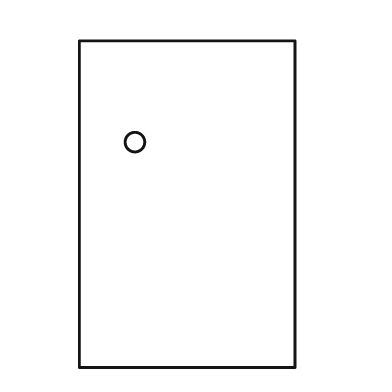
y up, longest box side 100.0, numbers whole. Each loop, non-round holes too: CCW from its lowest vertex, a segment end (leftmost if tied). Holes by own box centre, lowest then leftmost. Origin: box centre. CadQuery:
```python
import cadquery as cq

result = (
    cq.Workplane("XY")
    .moveTo(-33.0, -50.0)
    .lineTo(33.0, -50.0)
    .lineTo(33.0, 50.0)
    .lineTo(-33.0, 50.0)
    .close()
    .moveTo(-16.0, 19.0)
    .circle(3.0)
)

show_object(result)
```